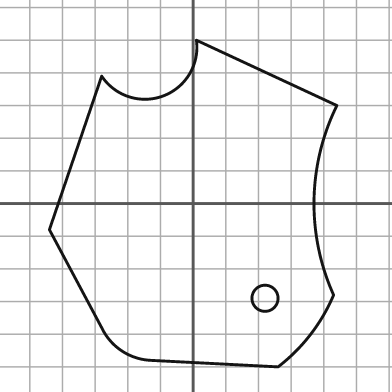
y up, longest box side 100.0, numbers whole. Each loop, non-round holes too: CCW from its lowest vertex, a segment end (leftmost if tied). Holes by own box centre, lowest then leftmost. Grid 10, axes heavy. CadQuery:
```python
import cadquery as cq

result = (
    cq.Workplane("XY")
    .moveTo(26.0, -50.0)
    .threePointArc((36.0, -40.0), (43.0, -28.0))
    .threePointArc((37.0, 1.0), (44.0, 30.0))
    .lineTo(1.0, 50.0)
    .threePointArc((-9.0, 33.0), (-28.0, 39.0))
    .lineTo(-44.0, -8.0)
    .lineTo(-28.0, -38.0)
    .threePointArc((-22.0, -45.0), (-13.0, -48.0))
    .close()
    .moveTo(22.0, -29.0)
    .circle(4.0)
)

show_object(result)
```